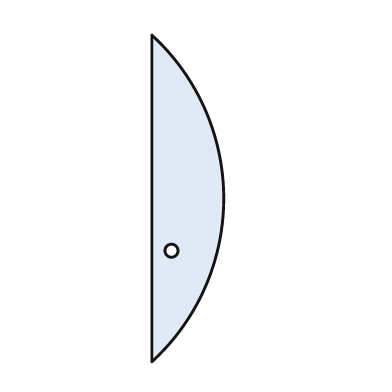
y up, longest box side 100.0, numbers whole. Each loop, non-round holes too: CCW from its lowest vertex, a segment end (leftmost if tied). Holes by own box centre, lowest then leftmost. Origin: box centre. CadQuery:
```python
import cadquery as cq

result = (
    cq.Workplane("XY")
    .moveTo(-11.0, -50.0)
    .threePointArc((11.0, 0.0), (-11.0, 50.0))
    .close()
    .moveTo(-5.0, -16.0)
    .circle(2.0)
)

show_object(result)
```